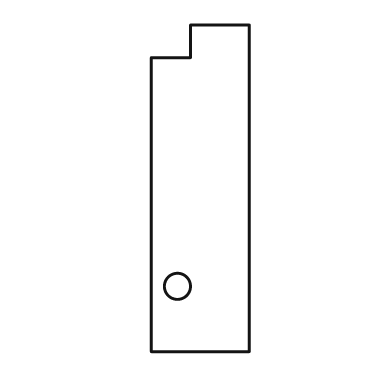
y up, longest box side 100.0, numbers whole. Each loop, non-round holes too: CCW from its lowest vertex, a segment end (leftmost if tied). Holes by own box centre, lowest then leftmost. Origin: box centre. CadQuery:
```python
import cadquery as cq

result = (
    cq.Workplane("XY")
    .moveTo(-15.0, -50.0)
    .lineTo(15.0, -50.0)
    .lineTo(15.0, 50.0)
    .lineTo(-3.0, 50.0)
    .lineTo(-3.0, 40.0)
    .lineTo(-15.0, 40.0)
    .close()
    .moveTo(-7.0, -30.0)
    .circle(4.0)
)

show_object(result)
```